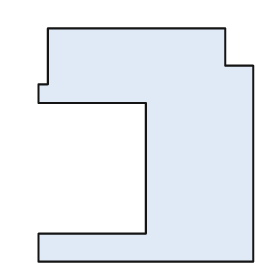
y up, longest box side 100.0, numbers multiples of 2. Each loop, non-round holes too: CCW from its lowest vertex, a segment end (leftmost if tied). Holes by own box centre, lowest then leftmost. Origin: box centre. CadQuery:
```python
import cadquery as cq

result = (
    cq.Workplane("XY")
    .moveTo(-46.0, -50.0)
    .lineTo(46.0, -50.0)
    .lineTo(46.0, 34.0)
    .lineTo(34.0, 34.0)
    .lineTo(34.0, 50.0)
    .lineTo(-42.0, 50.0)
    .lineTo(-42.0, 26.0)
    .lineTo(-46.0, 26.0)
    .lineTo(-46.0, 18.0)
    .lineTo(0.0, 18.0)
    .lineTo(0.0, -38.0)
    .lineTo(-46.0, -38.0)
    .close()
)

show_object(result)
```